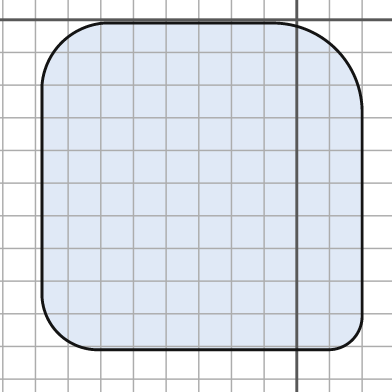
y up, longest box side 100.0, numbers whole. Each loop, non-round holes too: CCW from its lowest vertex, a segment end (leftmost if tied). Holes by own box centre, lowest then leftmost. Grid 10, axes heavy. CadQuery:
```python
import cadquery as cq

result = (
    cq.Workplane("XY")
    .moveTo(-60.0, -101.0)
    .lineTo(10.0, -101.0)
    .threePointArc((17.0, -98.0), (20.0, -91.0))
    .lineTo(20.0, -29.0)
    .threePointArc((12.0, -9.0), (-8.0, -1.0))
    .lineTo(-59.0, -1.0)
    .threePointArc((-72.0, -7.0), (-78.0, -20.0))
    .lineTo(-78.0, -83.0)
    .threePointArc((-73.0, -96.0), (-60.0, -101.0))
    .close()
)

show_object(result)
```